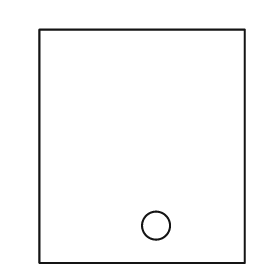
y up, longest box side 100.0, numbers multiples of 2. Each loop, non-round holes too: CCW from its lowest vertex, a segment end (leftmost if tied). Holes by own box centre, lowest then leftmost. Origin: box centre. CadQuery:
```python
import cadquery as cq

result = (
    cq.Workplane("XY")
    .moveTo(-44.0, -50.0)
    .lineTo(44.0, -50.0)
    .lineTo(44.0, 50.0)
    .lineTo(-44.0, 50.0)
    .close()
    .moveTo(6.0, -34.0)
    .circle(6.0)
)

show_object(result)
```